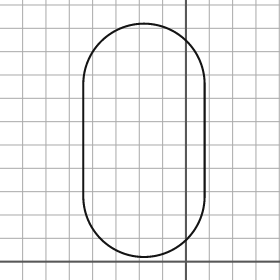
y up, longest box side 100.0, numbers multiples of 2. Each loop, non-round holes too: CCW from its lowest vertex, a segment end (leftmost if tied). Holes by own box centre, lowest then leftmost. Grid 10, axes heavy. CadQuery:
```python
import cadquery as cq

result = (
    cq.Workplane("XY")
    .moveTo(-44.0, 28.0)
    .threePointArc((-18.0, 2.0), (8.0, 28.0))
    .lineTo(8.0, 76.0)
    .threePointArc((-18.0, 102.0), (-44.0, 76.0))
    .close()
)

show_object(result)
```